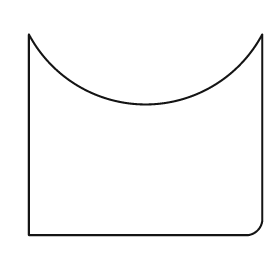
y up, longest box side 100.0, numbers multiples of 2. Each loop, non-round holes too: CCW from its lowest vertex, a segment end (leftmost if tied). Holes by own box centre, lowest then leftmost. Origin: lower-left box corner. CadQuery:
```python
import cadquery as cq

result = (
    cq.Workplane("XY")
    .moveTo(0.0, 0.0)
    .lineTo(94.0, 0.0)
    .threePointArc((98.0, 2.0), (100.0, 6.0))
    .lineTo(100.0, 86.0)
    .threePointArc((50.0, 56.0), (0.0, 86.0))
    .close()
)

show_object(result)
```